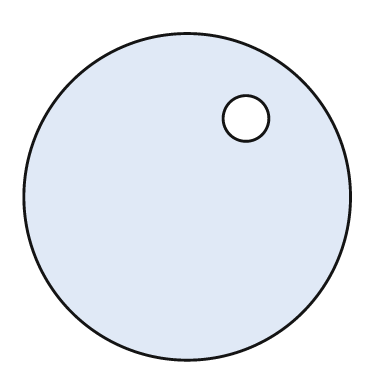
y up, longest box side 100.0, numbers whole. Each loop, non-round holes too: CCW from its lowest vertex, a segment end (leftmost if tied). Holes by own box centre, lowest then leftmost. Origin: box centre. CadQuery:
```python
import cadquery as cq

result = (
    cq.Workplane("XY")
    .moveTo(0.0, 0.0)
    .circle(50.0)
    .moveTo(18.0, 24.0)
    .circle(7.0)
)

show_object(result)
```